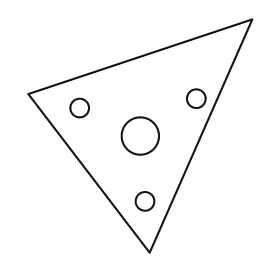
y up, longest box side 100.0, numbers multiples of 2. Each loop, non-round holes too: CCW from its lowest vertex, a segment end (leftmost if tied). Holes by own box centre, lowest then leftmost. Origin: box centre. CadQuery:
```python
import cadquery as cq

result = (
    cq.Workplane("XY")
    .moveTo(4.0, -50.0)
    .lineTo(48.0, 50.0)
    .lineTo(-48.0, 18.0)
    .close()
    .moveTo(2.0, -28.0)
    .circle(4.0)
    .moveTo(0.0, 0.0)
    .circle(8.0)
    .moveTo(-26.0, 12.0)
    .circle(4.0)
    .moveTo(24.0, 16.0)
    .circle(4.0)
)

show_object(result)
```